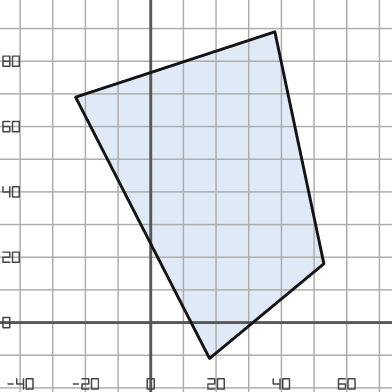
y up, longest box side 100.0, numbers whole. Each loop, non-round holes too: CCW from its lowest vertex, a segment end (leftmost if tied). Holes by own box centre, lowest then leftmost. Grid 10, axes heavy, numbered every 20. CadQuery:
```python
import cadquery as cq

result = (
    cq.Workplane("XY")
    .moveTo(18.0, -11.0)
    .lineTo(53.0, 18.0)
    .lineTo(38.0, 89.0)
    .lineTo(-23.0, 69.0)
    .close()
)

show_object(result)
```